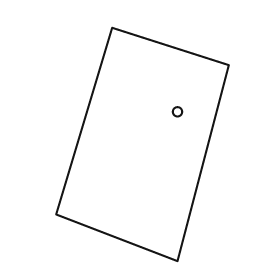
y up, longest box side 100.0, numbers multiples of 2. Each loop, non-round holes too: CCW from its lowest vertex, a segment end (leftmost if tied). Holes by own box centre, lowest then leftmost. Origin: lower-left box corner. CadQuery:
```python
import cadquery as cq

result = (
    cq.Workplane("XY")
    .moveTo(52.0, 0.0)
    .lineTo(74.0, 84.0)
    .lineTo(24.0, 100.0)
    .lineTo(0.0, 20.0)
    .close()
    .moveTo(52.0, 64.0)
    .circle(2.0)
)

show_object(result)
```